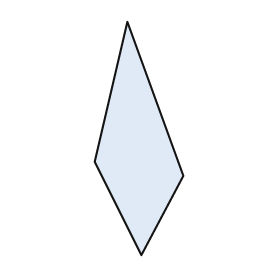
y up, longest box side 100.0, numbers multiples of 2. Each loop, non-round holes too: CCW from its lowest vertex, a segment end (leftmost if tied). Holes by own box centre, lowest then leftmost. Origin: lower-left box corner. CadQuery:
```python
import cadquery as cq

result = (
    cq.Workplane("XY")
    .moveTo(20.0, 0.0)
    .lineTo(38.0, 34.0)
    .lineTo(14.0, 100.0)
    .lineTo(0.0, 40.0)
    .close()
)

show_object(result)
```